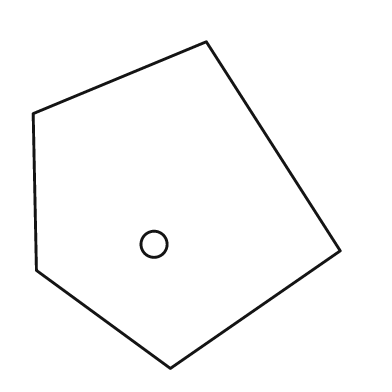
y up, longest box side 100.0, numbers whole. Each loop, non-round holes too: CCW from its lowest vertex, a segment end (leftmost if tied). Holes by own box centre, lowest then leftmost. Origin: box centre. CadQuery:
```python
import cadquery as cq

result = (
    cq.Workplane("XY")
    .moveTo(-5.0, -50.0)
    .lineTo(47.0, -14.0)
    .lineTo(6.0, 50.0)
    .lineTo(-47.0, 28.0)
    .lineTo(-46.0, -20.0)
    .close()
    .moveTo(-10.0, -12.0)
    .circle(4.0)
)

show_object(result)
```